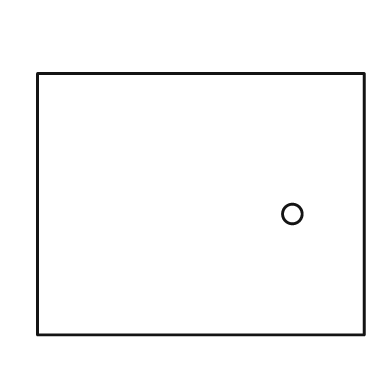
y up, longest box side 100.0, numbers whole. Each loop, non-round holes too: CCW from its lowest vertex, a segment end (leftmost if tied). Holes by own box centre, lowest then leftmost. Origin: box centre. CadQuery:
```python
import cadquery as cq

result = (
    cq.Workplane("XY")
    .moveTo(-50.0, -40.0)
    .lineTo(50.0, -40.0)
    .lineTo(50.0, 40.0)
    .lineTo(-50.0, 40.0)
    .close()
    .moveTo(28.0, -3.0)
    .circle(3.0)
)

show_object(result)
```